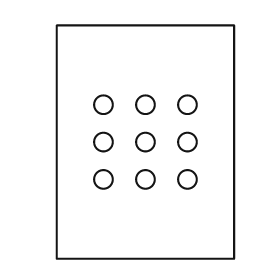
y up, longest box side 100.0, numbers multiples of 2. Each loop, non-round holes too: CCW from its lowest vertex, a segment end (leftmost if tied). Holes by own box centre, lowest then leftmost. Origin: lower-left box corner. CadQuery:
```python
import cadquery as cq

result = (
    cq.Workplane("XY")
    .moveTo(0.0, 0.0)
    .lineTo(76.0, 0.0)
    .lineTo(76.0, 100.0)
    .lineTo(0.0, 100.0)
    .close()
    .moveTo(20.0, 34.0)
    .circle(4.0)
    .moveTo(38.0, 34.0)
    .circle(4.0)
    .moveTo(56.0, 34.0)
    .circle(4.0)
    .moveTo(20.0, 50.0)
    .circle(4.0)
    .moveTo(38.0, 50.0)
    .circle(4.0)
    .moveTo(56.0, 50.0)
    .circle(4.0)
    .moveTo(20.0, 66.0)
    .circle(4.0)
    .moveTo(38.0, 66.0)
    .circle(4.0)
    .moveTo(56.0, 66.0)
    .circle(4.0)
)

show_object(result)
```